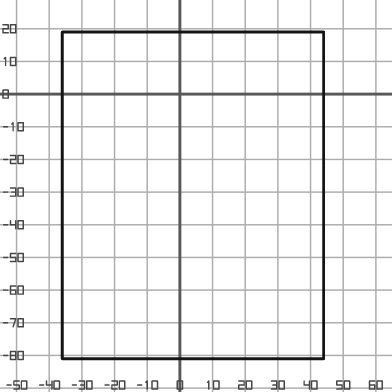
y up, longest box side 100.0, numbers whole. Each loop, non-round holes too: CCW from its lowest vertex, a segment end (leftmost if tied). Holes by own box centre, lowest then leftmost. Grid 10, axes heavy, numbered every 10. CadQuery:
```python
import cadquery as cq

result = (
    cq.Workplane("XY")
    .moveTo(-36.0, -81.0)
    .lineTo(44.0, -81.0)
    .lineTo(44.0, 19.0)
    .lineTo(-36.0, 19.0)
    .close()
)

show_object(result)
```